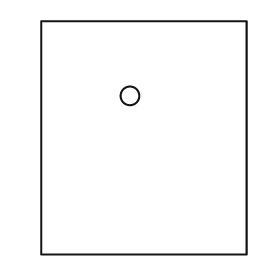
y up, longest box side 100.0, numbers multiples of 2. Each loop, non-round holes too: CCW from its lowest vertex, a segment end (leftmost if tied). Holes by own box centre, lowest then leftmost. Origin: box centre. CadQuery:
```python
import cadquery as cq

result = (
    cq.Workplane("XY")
    .moveTo(-44.0, -50.0)
    .lineTo(44.0, -50.0)
    .lineTo(44.0, 50.0)
    .lineTo(-44.0, 50.0)
    .close()
    .moveTo(-6.0, 18.0)
    .circle(4.0)
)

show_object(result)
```